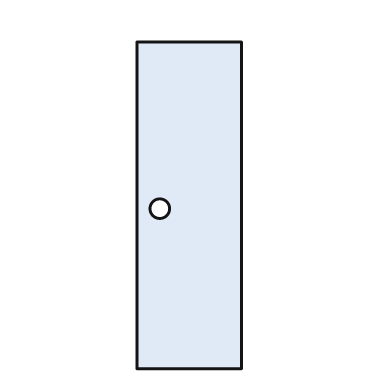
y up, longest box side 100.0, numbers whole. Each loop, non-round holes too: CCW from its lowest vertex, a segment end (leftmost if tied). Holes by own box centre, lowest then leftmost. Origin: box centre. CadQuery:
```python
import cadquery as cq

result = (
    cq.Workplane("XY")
    .moveTo(-16.0, -50.0)
    .lineTo(16.0, -50.0)
    .lineTo(16.0, 50.0)
    .lineTo(-16.0, 50.0)
    .close()
    .moveTo(-9.0, -1.0)
    .circle(3.0)
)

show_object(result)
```